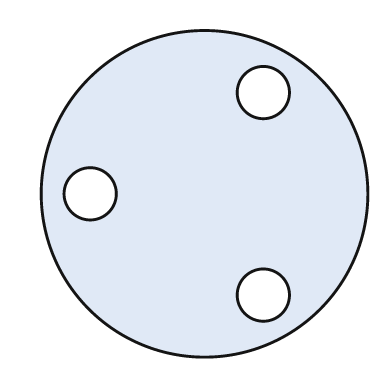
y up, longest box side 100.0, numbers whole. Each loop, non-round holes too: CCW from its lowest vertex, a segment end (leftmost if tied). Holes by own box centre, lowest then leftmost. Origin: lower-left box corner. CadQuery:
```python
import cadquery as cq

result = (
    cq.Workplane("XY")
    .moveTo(50.0, 50.0)
    .circle(50.0)
    .moveTo(68.0, 19.0)
    .circle(8.0)
    .moveTo(15.0, 50.0)
    .circle(8.0)
    .moveTo(68.0, 81.0)
    .circle(8.0)
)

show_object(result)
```